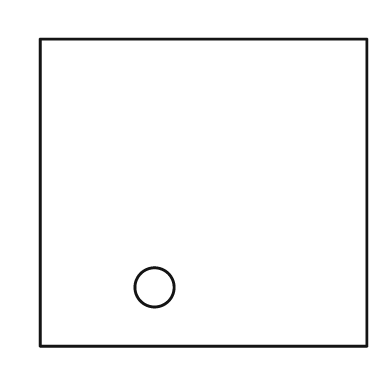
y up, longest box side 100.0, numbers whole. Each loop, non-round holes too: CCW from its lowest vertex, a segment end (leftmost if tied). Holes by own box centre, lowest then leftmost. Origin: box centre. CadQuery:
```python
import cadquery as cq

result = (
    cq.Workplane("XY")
    .moveTo(-50.0, -47.0)
    .lineTo(50.0, -47.0)
    .lineTo(50.0, 47.0)
    .lineTo(-50.0, 47.0)
    .close()
    .moveTo(-15.0, -29.0)
    .circle(6.0)
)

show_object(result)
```